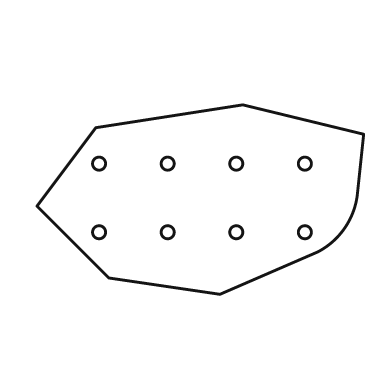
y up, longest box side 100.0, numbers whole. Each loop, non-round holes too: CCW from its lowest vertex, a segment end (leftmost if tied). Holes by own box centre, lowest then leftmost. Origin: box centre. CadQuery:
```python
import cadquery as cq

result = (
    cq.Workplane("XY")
    .moveTo(6.0, -29.0)
    .lineTo(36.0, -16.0)
    .threePointArc((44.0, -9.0), (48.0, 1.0))
    .lineTo(50.0, 20.0)
    .lineTo(13.0, 29.0)
    .lineTo(-32.0, 22.0)
    .lineTo(-50.0, -2.0)
    .lineTo(-28.0, -24.0)
    .close()
    .moveTo(-31.0, -10.0)
    .circle(2.0)
    .moveTo(-10.0, -10.0)
    .circle(2.0)
    .moveTo(11.0, -10.0)
    .circle(2.0)
    .moveTo(32.0, -10.0)
    .circle(2.0)
    .moveTo(-31.0, 11.0)
    .circle(2.0)
    .moveTo(-10.0, 11.0)
    .circle(2.0)
    .moveTo(11.0, 11.0)
    .circle(2.0)
    .moveTo(32.0, 11.0)
    .circle(2.0)
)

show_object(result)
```